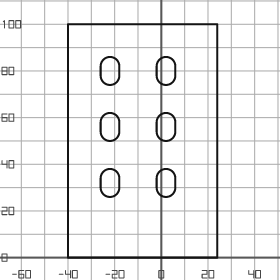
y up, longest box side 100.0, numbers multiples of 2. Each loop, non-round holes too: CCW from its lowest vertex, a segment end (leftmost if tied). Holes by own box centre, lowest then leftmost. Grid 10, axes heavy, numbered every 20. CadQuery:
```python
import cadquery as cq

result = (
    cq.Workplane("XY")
    .moveTo(-40.0, 0.0)
    .lineTo(24.0, 0.0)
    .lineTo(24.0, 100.0)
    .lineTo(-40.0, 100.0)
    .close()
    .moveTo(-26.0, 30.0)
    .threePointArc((-22.0, 26.0), (-18.0, 30.0))
    .lineTo(-18.0, 34.0)
    .threePointArc((-22.0, 38.0), (-26.0, 34.0))
    .close()
    .moveTo(-2.0, 30.0)
    .threePointArc((2.0, 26.0), (6.0, 30.0))
    .lineTo(6.0, 34.0)
    .threePointArc((2.0, 38.0), (-2.0, 34.0))
    .close()
    .moveTo(-26.0, 54.0)
    .threePointArc((-22.0, 50.0), (-18.0, 54.0))
    .lineTo(-18.0, 58.0)
    .threePointArc((-22.0, 62.0), (-26.0, 58.0))
    .close()
    .moveTo(-2.0, 54.0)
    .threePointArc((2.0, 50.0), (6.0, 54.0))
    .lineTo(6.0, 58.0)
    .threePointArc((2.0, 62.0), (-2.0, 58.0))
    .close()
    .moveTo(-26.0, 78.0)
    .threePointArc((-22.0, 74.0), (-18.0, 78.0))
    .lineTo(-18.0, 82.0)
    .threePointArc((-22.0, 86.0), (-26.0, 82.0))
    .close()
    .moveTo(-2.0, 78.0)
    .threePointArc((2.0, 74.0), (6.0, 78.0))
    .lineTo(6.0, 82.0)
    .threePointArc((2.0, 86.0), (-2.0, 82.0))
    .close()
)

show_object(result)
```